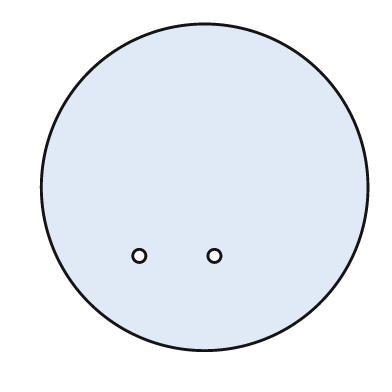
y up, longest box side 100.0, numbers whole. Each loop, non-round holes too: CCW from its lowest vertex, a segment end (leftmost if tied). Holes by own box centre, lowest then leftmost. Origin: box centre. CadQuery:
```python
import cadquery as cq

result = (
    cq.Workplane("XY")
    .moveTo(0.0, 0.0)
    .circle(50.0)
    .moveTo(-20.0, -21.0)
    .circle(2.0)
    .moveTo(3.0, -21.0)
    .circle(2.0)
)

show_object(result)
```